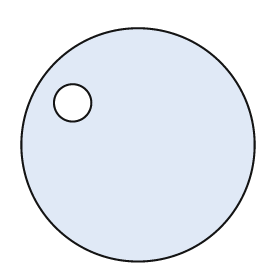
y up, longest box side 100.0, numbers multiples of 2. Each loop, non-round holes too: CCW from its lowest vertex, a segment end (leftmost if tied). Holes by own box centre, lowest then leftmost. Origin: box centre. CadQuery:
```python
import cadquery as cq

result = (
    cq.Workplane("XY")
    .moveTo(0.0, 0.0)
    .circle(50.0)
    .moveTo(-28.0, 18.0)
    .circle(8.0)
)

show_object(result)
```